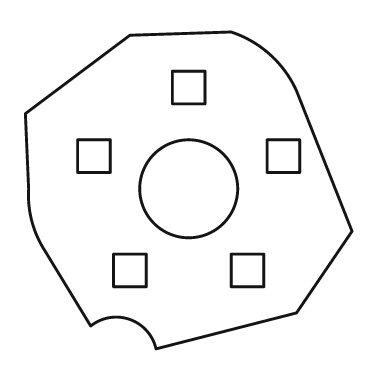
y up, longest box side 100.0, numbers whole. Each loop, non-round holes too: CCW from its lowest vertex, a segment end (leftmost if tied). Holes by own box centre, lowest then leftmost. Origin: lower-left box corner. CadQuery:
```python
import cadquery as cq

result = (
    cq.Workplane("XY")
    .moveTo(40.0, 0.0)
    .lineTo(83.0, 11.0)
    .lineTo(100.0, 36.0)
    .lineTo(83.0, 79.0)
    .threePointArc((75.0, 90.0), (63.0, 97.0))
    .lineTo(32.0, 96.0)
    .lineTo(0.0, 72.0)
    .lineTo(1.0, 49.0)
    .threePointArc((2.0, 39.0), (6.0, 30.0))
    .lineTo(20.0, 7.0)
    .threePointArc((32.0, 9.0), (40.0, 0.0))
    .close()
    .moveTo(27.0, 19.0)
    .lineTo(37.0, 19.0)
    .lineTo(37.0, 29.0)
    .lineTo(27.0, 29.0)
    .close()
    .moveTo(63.0, 19.0)
    .lineTo(73.0, 19.0)
    .lineTo(73.0, 29.0)
    .lineTo(63.0, 29.0)
    .close()
    .moveTo(50.0, 49.0)
    .circle(15.0)
    .moveTo(16.0, 54.0)
    .lineTo(26.0, 54.0)
    .lineTo(26.0, 64.0)
    .lineTo(16.0, 64.0)
    .close()
    .moveTo(74.0, 54.0)
    .lineTo(84.0, 54.0)
    .lineTo(84.0, 64.0)
    .lineTo(74.0, 64.0)
    .close()
    .moveTo(45.0, 75.0)
    .lineTo(55.0, 75.0)
    .lineTo(55.0, 85.0)
    .lineTo(45.0, 85.0)
    .close()
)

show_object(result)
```